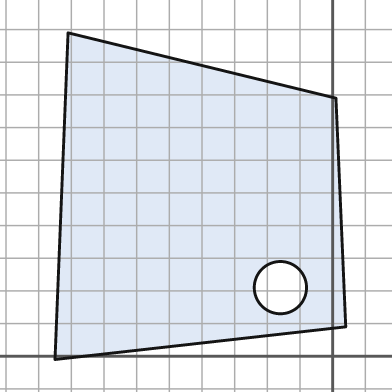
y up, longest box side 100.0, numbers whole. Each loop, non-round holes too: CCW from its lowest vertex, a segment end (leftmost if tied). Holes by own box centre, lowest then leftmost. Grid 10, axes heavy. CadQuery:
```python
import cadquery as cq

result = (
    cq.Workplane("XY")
    .moveTo(-85.0, -1.0)
    .lineTo(4.0, 9.0)
    .lineTo(1.0, 79.0)
    .lineTo(-81.0, 99.0)
    .close()
    .moveTo(-16.0, 21.0)
    .circle(8.0)
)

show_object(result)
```